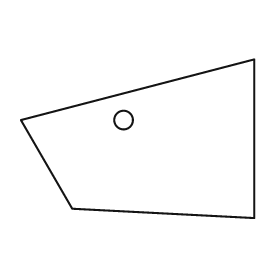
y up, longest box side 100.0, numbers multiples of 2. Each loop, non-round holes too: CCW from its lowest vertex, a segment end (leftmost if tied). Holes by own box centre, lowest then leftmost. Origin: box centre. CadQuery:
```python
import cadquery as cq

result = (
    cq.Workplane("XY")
    .moveTo(50.0, -34.0)
    .lineTo(50.0, 34.0)
    .lineTo(-50.0, 8.0)
    .lineTo(-28.0, -30.0)
    .close()
    .moveTo(-6.0, 8.0)
    .circle(4.0)
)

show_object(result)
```